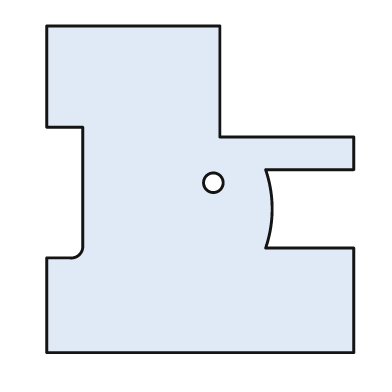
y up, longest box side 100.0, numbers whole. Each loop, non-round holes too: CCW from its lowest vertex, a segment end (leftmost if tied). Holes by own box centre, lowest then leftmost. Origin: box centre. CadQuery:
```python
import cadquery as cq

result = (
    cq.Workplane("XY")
    .moveTo(-47.0, -50.0)
    .lineTo(47.0, -50.0)
    .lineTo(47.0, -18.0)
    .lineTo(20.0, -18.0)
    .threePointArc((22.0, -6.0), (20.0, 6.0))
    .lineTo(47.0, 6.0)
    .lineTo(47.0, 16.0)
    .lineTo(6.0, 16.0)
    .lineTo(6.0, 50.0)
    .lineTo(-47.0, 50.0)
    .lineTo(-47.0, 19.0)
    .lineTo(-36.0, 19.0)
    .lineTo(-36.0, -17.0)
    .threePointArc((-37.0, -20.0), (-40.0, -21.0))
    .lineTo(-47.0, -21.0)
    .close()
    .moveTo(4.0, 2.0)
    .circle(3.0)
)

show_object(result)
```